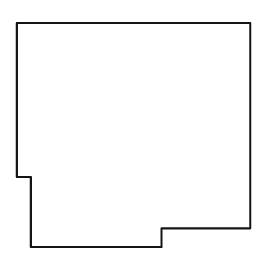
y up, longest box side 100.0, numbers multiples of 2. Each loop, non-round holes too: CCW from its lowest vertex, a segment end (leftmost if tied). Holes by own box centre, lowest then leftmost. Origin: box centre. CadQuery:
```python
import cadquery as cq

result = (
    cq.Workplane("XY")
    .moveTo(-44.0, -48.0)
    .lineTo(12.0, -48.0)
    .lineTo(12.0, -40.0)
    .lineTo(50.0, -40.0)
    .lineTo(50.0, 48.0)
    .lineTo(-50.0, 48.0)
    .lineTo(-50.0, -18.0)
    .lineTo(-44.0, -18.0)
    .close()
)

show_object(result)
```